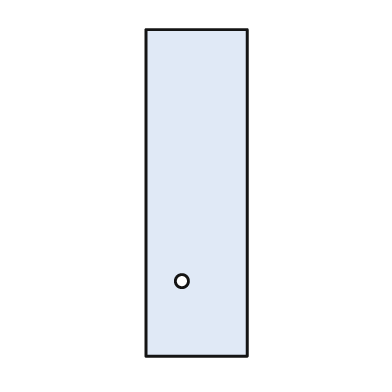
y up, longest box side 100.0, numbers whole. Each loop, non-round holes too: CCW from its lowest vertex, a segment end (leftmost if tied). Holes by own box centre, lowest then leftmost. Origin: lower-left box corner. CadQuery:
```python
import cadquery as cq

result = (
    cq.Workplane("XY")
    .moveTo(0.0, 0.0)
    .lineTo(31.0, 0.0)
    .lineTo(31.0, 100.0)
    .lineTo(0.0, 100.0)
    .close()
    .moveTo(11.0, 23.0)
    .circle(2.0)
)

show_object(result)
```